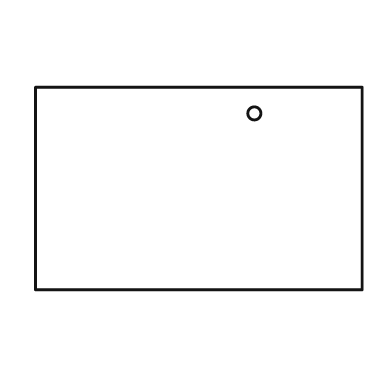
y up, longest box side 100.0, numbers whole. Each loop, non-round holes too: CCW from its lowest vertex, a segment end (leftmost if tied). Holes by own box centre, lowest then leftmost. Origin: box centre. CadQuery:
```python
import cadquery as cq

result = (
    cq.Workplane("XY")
    .moveTo(-50.0, -31.0)
    .lineTo(50.0, -31.0)
    .lineTo(50.0, 31.0)
    .lineTo(-50.0, 31.0)
    .close()
    .moveTo(17.0, 23.0)
    .circle(2.0)
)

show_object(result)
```